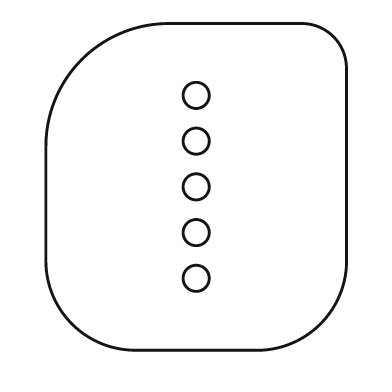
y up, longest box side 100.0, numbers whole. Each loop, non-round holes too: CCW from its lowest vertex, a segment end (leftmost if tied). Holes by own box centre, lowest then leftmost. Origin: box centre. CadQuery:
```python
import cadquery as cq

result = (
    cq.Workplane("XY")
    .moveTo(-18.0, -50.0)
    .lineTo(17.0, -50.0)
    .threePointArc((38.0, -42.0), (46.0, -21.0))
    .lineTo(46.0, 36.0)
    .threePointArc((42.0, 46.0), (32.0, 50.0))
    .lineTo(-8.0, 50.0)
    .threePointArc((-35.0, 39.0), (-46.0, 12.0))
    .lineTo(-46.0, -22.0)
    .threePointArc((-38.0, -42.0), (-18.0, -50.0))
    .close()
    .moveTo(0.0, -28.0)
    .circle(4.0)
    .moveTo(0.0, -14.0)
    .circle(4.0)
    .moveTo(0.0, 0.0)
    .circle(4.0)
    .moveTo(0.0, 14.0)
    .circle(4.0)
    .moveTo(0.0, 28.0)
    .circle(4.0)
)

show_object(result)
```